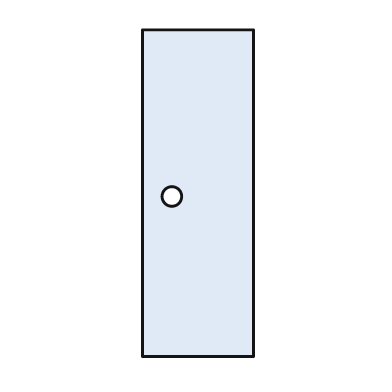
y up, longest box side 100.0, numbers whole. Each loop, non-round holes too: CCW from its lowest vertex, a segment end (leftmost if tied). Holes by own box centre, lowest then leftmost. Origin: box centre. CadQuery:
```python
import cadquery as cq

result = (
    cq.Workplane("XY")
    .moveTo(-17.0, -50.0)
    .lineTo(17.0, -50.0)
    .lineTo(17.0, 50.0)
    .lineTo(-17.0, 50.0)
    .close()
    .moveTo(-8.0, -1.0)
    .circle(3.0)
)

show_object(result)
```